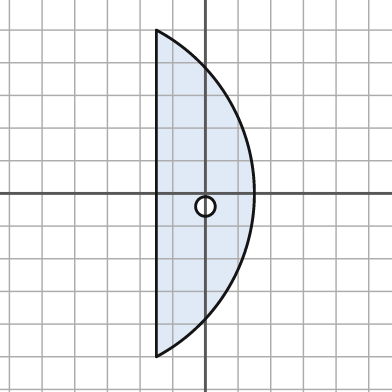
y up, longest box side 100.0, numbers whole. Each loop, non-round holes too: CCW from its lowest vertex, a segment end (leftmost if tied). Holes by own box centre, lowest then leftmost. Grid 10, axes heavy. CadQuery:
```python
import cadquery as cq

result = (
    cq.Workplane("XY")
    .moveTo(-15.0, -50.0)
    .threePointArc((15.0, 0.0), (-15.0, 50.0))
    .close()
    .moveTo(0.0, -4.0)
    .circle(3.0)
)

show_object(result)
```